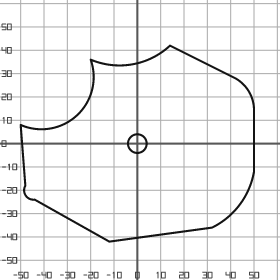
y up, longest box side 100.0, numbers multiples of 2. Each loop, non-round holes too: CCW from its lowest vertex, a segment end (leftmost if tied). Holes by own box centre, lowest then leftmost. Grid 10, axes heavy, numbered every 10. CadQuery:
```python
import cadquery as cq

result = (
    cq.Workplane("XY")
    .moveTo(-12.0, -42.0)
    .lineTo(32.0, -36.0)
    .threePointArc((44.0, -26.0), (50.0, -12.0))
    .lineTo(50.0, 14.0)
    .threePointArc((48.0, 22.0), (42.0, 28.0))
    .lineTo(14.0, 42.0)
    .threePointArc((-2.0, 34.0), (-20.0, 36.0))
    .threePointArc((-26.0, 12.0), (-50.0, 8.0))
    .lineTo(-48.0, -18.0)
    .threePointArc((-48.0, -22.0), (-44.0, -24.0))
    .close()
    .moveTo(0.0, 0.0)
    .circle(4.0)
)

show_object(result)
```